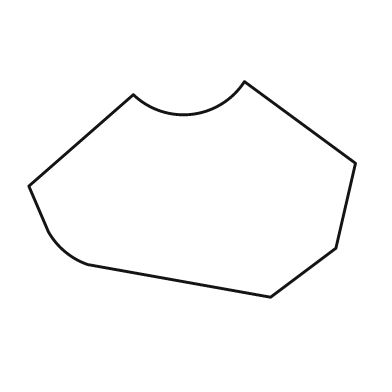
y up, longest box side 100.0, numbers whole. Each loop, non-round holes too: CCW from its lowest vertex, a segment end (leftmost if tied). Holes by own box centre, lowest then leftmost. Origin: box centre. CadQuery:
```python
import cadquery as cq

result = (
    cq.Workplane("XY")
    .moveTo(24.0, -33.0)
    .lineTo(44.0, -18.0)
    .lineTo(50.0, 8.0)
    .lineTo(16.0, 33.0)
    .threePointArc((0.0, 23.0), (-18.0, 29.0))
    .lineTo(-50.0, 1.0)
    .lineTo(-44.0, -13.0)
    .threePointArc((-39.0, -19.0), (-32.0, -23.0))
    .close()
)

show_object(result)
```